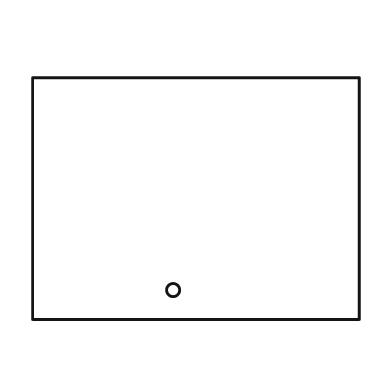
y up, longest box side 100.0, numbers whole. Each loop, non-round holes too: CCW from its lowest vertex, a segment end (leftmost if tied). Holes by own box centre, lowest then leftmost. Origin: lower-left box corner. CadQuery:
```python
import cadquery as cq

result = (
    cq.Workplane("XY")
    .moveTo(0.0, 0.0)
    .lineTo(100.0, 0.0)
    .lineTo(100.0, 74.0)
    .lineTo(0.0, 74.0)
    .close()
    .moveTo(43.0, 9.0)
    .circle(2.0)
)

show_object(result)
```